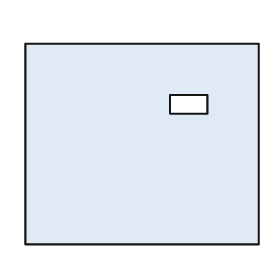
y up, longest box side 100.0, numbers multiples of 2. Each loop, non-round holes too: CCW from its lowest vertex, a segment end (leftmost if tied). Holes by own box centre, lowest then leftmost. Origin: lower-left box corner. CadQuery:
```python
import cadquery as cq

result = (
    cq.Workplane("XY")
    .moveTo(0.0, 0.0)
    .lineTo(100.0, 0.0)
    .lineTo(100.0, 86.0)
    .lineTo(0.0, 86.0)
    .close()
    .moveTo(62.0, 56.0)
    .lineTo(78.0, 56.0)
    .lineTo(78.0, 64.0)
    .lineTo(62.0, 64.0)
    .close()
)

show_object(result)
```